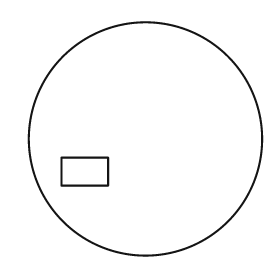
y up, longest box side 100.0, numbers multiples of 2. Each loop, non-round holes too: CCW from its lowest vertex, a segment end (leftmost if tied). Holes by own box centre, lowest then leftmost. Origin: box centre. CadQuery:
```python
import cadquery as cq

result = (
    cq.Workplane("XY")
    .moveTo(0.0, 0.0)
    .circle(50.0)
    .moveTo(-36.0, -20.0)
    .lineTo(-16.0, -20.0)
    .lineTo(-16.0, -8.0)
    .lineTo(-36.0, -8.0)
    .close()
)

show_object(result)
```